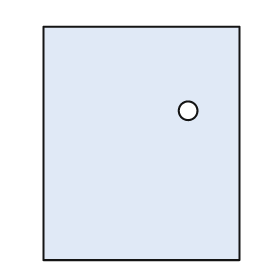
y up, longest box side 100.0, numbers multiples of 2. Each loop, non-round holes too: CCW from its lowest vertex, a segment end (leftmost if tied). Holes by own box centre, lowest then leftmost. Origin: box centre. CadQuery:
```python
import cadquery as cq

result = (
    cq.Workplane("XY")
    .moveTo(-42.0, -50.0)
    .lineTo(42.0, -50.0)
    .lineTo(42.0, 50.0)
    .lineTo(-42.0, 50.0)
    .close()
    .moveTo(20.0, 14.0)
    .circle(4.0)
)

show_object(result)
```